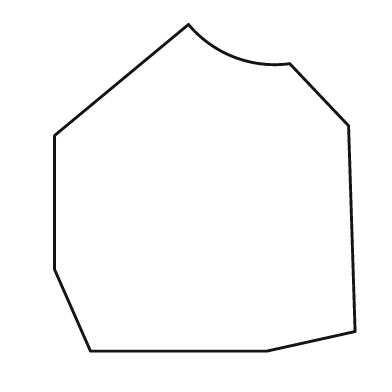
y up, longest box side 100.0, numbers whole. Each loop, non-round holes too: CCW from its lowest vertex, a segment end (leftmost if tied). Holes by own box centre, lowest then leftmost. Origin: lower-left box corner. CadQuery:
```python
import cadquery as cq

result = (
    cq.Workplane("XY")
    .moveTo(11.0, 0.0)
    .lineTo(65.0, 0.0)
    .lineTo(92.0, 6.0)
    .lineTo(90.0, 69.0)
    .lineTo(72.0, 88.0)
    .threePointArc((55.0, 90.0), (41.0, 100.0))
    .lineTo(0.0, 66.0)
    .lineTo(0.0, 25.0)
    .close()
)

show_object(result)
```